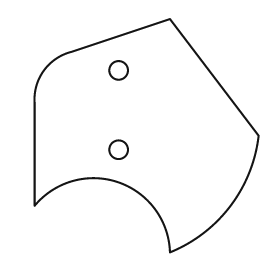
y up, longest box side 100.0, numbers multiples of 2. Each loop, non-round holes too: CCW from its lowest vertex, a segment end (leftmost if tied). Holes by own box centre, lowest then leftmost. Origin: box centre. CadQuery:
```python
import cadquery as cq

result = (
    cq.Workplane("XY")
    .moveTo(10.0, -50.0)
    .threePointArc((36.0, -30.0), (48.0, 0.0))
    .lineTo(10.0, 50.0)
    .lineTo(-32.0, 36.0)
    .threePointArc((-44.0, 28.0), (-48.0, 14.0))
    .lineTo(-48.0, -30.0)
    .threePointArc((-12.0, -20.0), (10.0, -50.0))
    .close()
    .moveTo(-12.0, -6.0)
    .circle(4.0)
    .moveTo(-12.0, 28.0)
    .circle(4.0)
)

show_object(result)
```